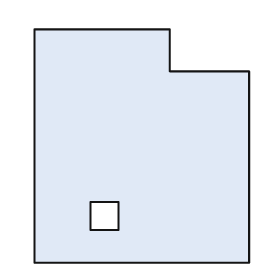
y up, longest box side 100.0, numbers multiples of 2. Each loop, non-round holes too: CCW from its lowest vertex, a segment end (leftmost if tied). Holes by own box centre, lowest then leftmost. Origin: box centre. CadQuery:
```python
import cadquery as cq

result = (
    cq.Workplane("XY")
    .moveTo(-46.0, -50.0)
    .lineTo(46.0, -50.0)
    .lineTo(46.0, 32.0)
    .lineTo(12.0, 32.0)
    .lineTo(12.0, 50.0)
    .lineTo(-46.0, 50.0)
    .close()
    .moveTo(-22.0, -36.0)
    .lineTo(-10.0, -36.0)
    .lineTo(-10.0, -24.0)
    .lineTo(-22.0, -24.0)
    .close()
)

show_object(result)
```